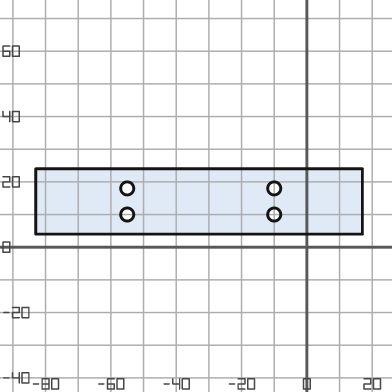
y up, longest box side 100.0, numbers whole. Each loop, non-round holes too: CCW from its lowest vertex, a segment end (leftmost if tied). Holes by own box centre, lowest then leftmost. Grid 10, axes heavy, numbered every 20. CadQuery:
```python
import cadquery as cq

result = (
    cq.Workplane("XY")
    .moveTo(-83.0, 4.0)
    .lineTo(17.0, 4.0)
    .lineTo(17.0, 24.0)
    .lineTo(-83.0, 24.0)
    .close()
    .moveTo(-55.0, 10.0)
    .circle(2.0)
    .moveTo(-10.0, 10.0)
    .circle(2.0)
    .moveTo(-55.0, 18.0)
    .circle(2.0)
    .moveTo(-10.0, 18.0)
    .circle(2.0)
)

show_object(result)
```